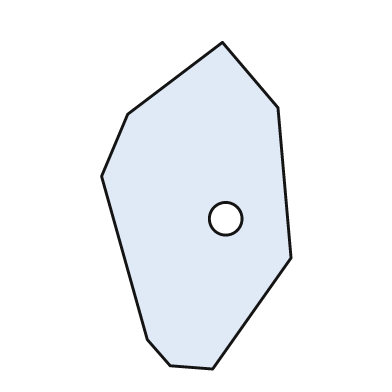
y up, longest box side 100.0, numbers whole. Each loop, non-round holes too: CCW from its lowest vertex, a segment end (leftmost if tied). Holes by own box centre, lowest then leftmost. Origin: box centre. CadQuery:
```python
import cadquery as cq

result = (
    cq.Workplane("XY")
    .moveTo(5.0, -50.0)
    .lineTo(29.0, -16.0)
    .lineTo(25.0, 30.0)
    .lineTo(8.0, 50.0)
    .lineTo(-21.0, 28.0)
    .lineTo(-29.0, 9.0)
    .lineTo(-15.0, -41.0)
    .lineTo(-8.0, -49.0)
    .close()
    .moveTo(9.0, -4.0)
    .circle(5.0)
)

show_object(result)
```